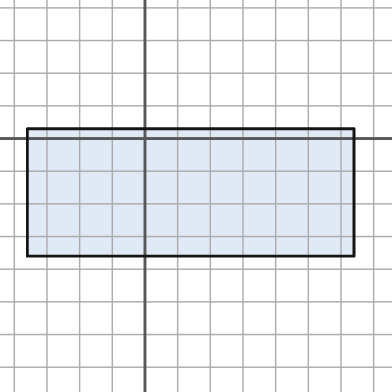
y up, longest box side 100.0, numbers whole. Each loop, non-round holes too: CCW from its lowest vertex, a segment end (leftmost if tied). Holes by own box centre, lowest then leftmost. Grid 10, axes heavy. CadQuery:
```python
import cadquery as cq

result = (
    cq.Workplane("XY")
    .moveTo(-36.0, -36.0)
    .lineTo(64.0, -36.0)
    .lineTo(64.0, 3.0)
    .lineTo(-36.0, 3.0)
    .close()
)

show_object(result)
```